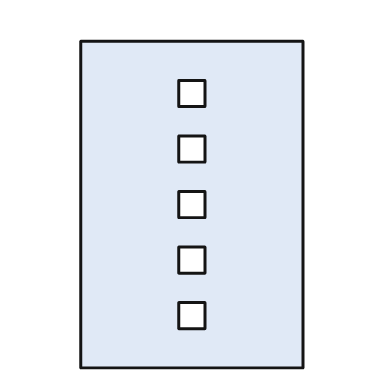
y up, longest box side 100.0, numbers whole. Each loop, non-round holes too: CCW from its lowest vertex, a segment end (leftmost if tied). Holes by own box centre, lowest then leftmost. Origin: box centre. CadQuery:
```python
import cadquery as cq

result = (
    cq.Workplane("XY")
    .moveTo(-34.0, -50.0)
    .lineTo(34.0, -50.0)
    .lineTo(34.0, 50.0)
    .lineTo(-34.0, 50.0)
    .close()
    .moveTo(-4.0, -38.0)
    .lineTo(4.0, -38.0)
    .lineTo(4.0, -30.0)
    .lineTo(-4.0, -30.0)
    .close()
    .moveTo(-4.0, -21.0)
    .lineTo(4.0, -21.0)
    .lineTo(4.0, -13.0)
    .lineTo(-4.0, -13.0)
    .close()
    .moveTo(-4.0, -4.0)
    .lineTo(4.0, -4.0)
    .lineTo(4.0, 4.0)
    .lineTo(-4.0, 4.0)
    .close()
    .moveTo(-4.0, 13.0)
    .lineTo(4.0, 13.0)
    .lineTo(4.0, 21.0)
    .lineTo(-4.0, 21.0)
    .close()
    .moveTo(-4.0, 30.0)
    .lineTo(4.0, 30.0)
    .lineTo(4.0, 38.0)
    .lineTo(-4.0, 38.0)
    .close()
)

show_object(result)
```